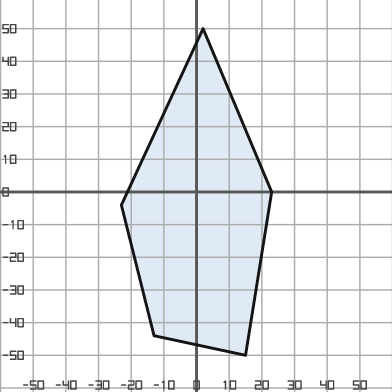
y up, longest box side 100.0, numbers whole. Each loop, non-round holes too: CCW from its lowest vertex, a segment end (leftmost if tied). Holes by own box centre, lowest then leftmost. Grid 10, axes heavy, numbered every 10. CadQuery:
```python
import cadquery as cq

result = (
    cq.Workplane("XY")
    .moveTo(15.0, -50.0)
    .lineTo(23.0, 0.0)
    .lineTo(2.0, 50.0)
    .lineTo(-23.0, -4.0)
    .lineTo(-13.0, -44.0)
    .close()
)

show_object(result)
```